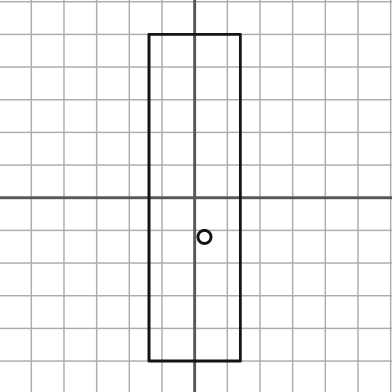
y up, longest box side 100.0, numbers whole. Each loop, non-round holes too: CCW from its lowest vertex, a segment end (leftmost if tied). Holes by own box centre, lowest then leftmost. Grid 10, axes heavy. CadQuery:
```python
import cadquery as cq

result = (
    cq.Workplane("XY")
    .moveTo(-14.0, -50.0)
    .lineTo(14.0, -50.0)
    .lineTo(14.0, 50.0)
    .lineTo(-14.0, 50.0)
    .close()
    .moveTo(3.0, -12.0)
    .circle(2.0)
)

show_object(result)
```